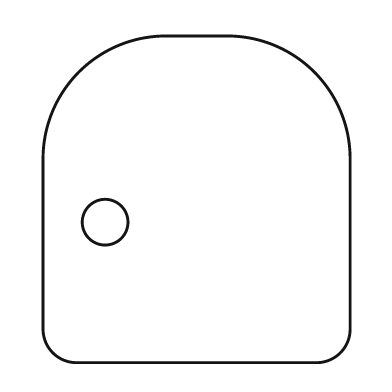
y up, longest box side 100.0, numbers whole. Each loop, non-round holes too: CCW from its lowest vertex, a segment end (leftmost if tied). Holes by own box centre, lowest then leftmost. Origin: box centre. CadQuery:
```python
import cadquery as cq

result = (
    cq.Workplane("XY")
    .moveTo(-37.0, -50.0)
    .lineTo(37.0, -50.0)
    .threePointArc((44.0, -47.0), (47.0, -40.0))
    .lineTo(47.0, 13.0)
    .threePointArc((36.0, 39.0), (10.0, 50.0))
    .lineTo(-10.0, 50.0)
    .threePointArc((-36.0, 39.0), (-47.0, 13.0))
    .lineTo(-47.0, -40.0)
    .threePointArc((-44.0, -47.0), (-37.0, -50.0))
    .close()
    .moveTo(-28.0, -7.0)
    .circle(7.0)
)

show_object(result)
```